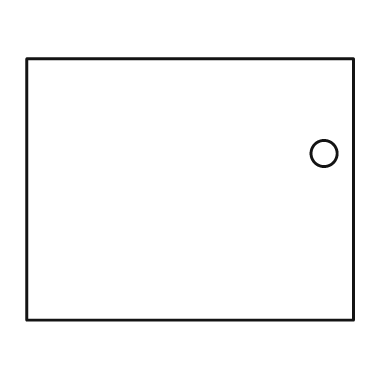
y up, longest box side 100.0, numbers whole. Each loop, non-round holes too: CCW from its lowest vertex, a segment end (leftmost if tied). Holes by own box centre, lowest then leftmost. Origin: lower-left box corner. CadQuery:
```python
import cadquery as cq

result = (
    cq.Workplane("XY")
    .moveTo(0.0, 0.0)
    .lineTo(100.0, 0.0)
    .lineTo(100.0, 80.0)
    .lineTo(0.0, 80.0)
    .close()
    .moveTo(91.0, 51.0)
    .circle(4.0)
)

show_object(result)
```